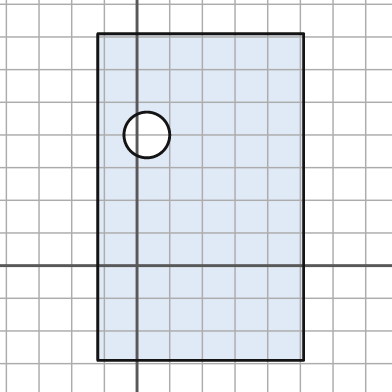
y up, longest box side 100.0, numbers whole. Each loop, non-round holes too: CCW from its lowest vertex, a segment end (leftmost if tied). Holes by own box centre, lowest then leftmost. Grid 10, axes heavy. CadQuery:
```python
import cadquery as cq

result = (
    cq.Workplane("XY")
    .moveTo(-12.0, -29.0)
    .lineTo(51.0, -29.0)
    .lineTo(51.0, 71.0)
    .lineTo(-12.0, 71.0)
    .close()
    .moveTo(3.0, 40.0)
    .circle(7.0)
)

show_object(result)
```